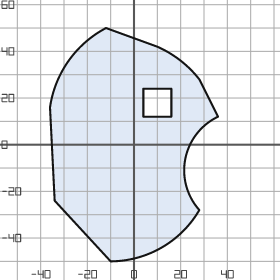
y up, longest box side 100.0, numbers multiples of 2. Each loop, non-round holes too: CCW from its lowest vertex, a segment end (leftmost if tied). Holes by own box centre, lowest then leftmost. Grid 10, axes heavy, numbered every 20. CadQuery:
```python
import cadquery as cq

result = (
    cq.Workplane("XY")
    .moveTo(-10.0, -50.0)
    .threePointArc((12.0, -44.0), (28.0, -28.0))
    .threePointArc((22.0, -6.0), (36.0, 12.0))
    .lineTo(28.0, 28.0)
    .threePointArc((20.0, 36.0), (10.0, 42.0))
    .lineTo(-12.0, 50.0)
    .threePointArc((-28.0, 36.0), (-36.0, 16.0))
    .lineTo(-34.0, -24.0)
    .close()
    .moveTo(4.0, 12.0)
    .lineTo(16.0, 12.0)
    .lineTo(16.0, 24.0)
    .lineTo(4.0, 24.0)
    .close()
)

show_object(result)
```